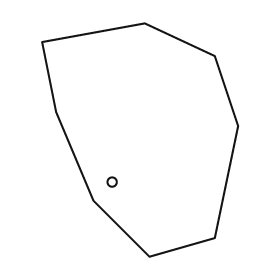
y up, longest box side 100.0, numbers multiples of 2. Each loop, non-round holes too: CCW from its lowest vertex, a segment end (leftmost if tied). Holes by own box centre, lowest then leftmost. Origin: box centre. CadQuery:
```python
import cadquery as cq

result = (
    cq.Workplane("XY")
    .moveTo(4.0, -50.0)
    .lineTo(32.0, -42.0)
    .lineTo(42.0, 6.0)
    .lineTo(32.0, 36.0)
    .lineTo(2.0, 50.0)
    .lineTo(-42.0, 42.0)
    .lineTo(-36.0, 12.0)
    .lineTo(-20.0, -26.0)
    .close()
    .moveTo(-12.0, -18.0)
    .circle(2.0)
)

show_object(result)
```